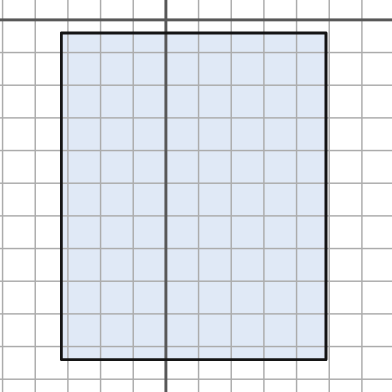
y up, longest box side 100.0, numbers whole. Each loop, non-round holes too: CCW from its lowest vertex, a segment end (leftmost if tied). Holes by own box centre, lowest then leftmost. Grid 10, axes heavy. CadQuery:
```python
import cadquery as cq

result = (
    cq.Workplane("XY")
    .moveTo(-32.0, -104.0)
    .lineTo(49.0, -104.0)
    .lineTo(49.0, -4.0)
    .lineTo(-32.0, -4.0)
    .close()
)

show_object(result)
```